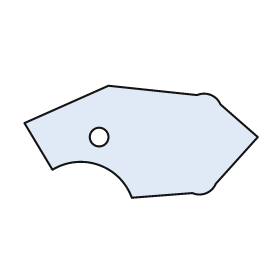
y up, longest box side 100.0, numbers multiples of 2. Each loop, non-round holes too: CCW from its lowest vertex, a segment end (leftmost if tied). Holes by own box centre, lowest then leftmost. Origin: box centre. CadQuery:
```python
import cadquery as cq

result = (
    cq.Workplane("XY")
    .moveTo(-4.0, -24.0)
    .lineTo(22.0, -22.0)
    .threePointArc((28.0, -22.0), (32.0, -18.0))
    .lineTo(50.0, 2.0)
    .lineTo(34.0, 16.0)
    .threePointArc((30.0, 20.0), (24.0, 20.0))
    .lineTo(-14.0, 24.0)
    .lineTo(-50.0, 8.0)
    .lineTo(-38.0, -12.0)
    .threePointArc((-18.0, -10.0), (-4.0, -24.0))
    .close()
    .moveTo(-18.0, 2.0)
    .circle(4.0)
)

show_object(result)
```